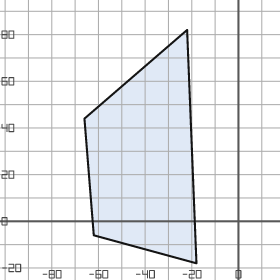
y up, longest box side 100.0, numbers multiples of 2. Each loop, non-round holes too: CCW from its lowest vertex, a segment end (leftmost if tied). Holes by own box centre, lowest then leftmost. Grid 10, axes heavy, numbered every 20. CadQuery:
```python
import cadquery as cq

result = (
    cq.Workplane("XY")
    .moveTo(-18.0, -18.0)
    .lineTo(-22.0, 82.0)
    .lineTo(-66.0, 44.0)
    .lineTo(-62.0, -6.0)
    .close()
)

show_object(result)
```